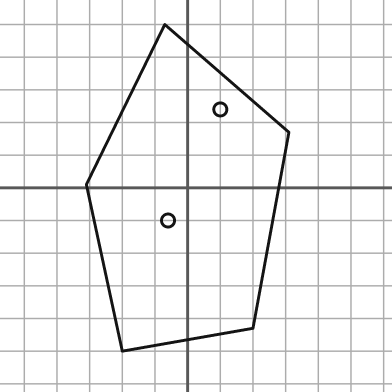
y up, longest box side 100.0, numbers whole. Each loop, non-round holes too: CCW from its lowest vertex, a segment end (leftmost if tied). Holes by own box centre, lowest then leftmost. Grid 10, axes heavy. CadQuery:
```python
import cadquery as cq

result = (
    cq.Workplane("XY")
    .moveTo(-20.0, -50.0)
    .lineTo(20.0, -43.0)
    .lineTo(31.0, 17.0)
    .lineTo(-7.0, 50.0)
    .lineTo(-31.0, 1.0)
    .close()
    .moveTo(-6.0, -10.0)
    .circle(2.0)
    .moveTo(10.0, 24.0)
    .circle(2.0)
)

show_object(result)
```